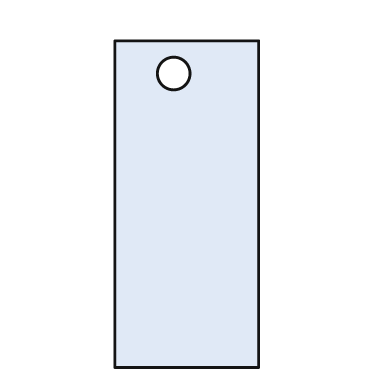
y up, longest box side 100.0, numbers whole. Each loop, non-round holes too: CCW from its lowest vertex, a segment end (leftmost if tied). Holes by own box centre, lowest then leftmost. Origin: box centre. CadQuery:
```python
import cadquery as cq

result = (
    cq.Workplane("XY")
    .moveTo(-22.0, -50.0)
    .lineTo(22.0, -50.0)
    .lineTo(22.0, 50.0)
    .lineTo(-22.0, 50.0)
    .close()
    .moveTo(-4.0, 40.0)
    .circle(5.0)
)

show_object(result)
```